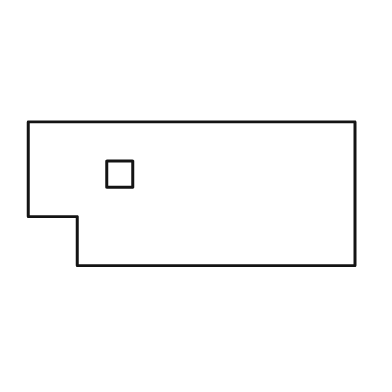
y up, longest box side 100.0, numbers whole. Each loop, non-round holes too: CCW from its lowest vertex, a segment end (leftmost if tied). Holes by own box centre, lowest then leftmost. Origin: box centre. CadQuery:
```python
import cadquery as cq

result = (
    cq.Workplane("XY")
    .moveTo(-35.0, -22.0)
    .lineTo(50.0, -22.0)
    .lineTo(50.0, 22.0)
    .lineTo(-50.0, 22.0)
    .lineTo(-50.0, -7.0)
    .lineTo(-35.0, -7.0)
    .close()
    .moveTo(-26.0, 2.0)
    .lineTo(-18.0, 2.0)
    .lineTo(-18.0, 10.0)
    .lineTo(-26.0, 10.0)
    .close()
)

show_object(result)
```